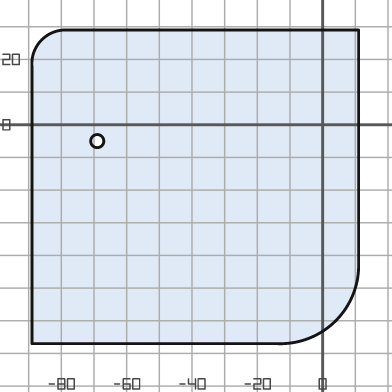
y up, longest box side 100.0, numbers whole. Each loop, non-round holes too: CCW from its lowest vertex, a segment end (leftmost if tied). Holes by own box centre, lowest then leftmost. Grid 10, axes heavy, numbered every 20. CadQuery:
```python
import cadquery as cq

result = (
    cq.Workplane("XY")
    .moveTo(-89.0, -67.0)
    .lineTo(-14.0, -67.0)
    .threePointArc((4.0, -60.0), (11.0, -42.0))
    .lineTo(11.0, 29.0)
    .lineTo(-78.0, 29.0)
    .threePointArc((-86.0, 26.0), (-89.0, 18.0))
    .close()
    .moveTo(-69.0, -5.0)
    .circle(2.0)
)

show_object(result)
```